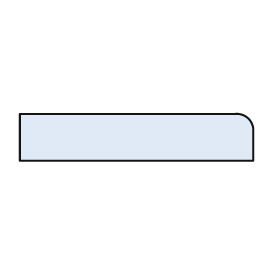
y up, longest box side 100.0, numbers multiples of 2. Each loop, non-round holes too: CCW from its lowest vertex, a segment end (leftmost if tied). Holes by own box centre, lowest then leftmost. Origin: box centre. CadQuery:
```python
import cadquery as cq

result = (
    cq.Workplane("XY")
    .moveTo(-50.0, -10.0)
    .lineTo(50.0, -10.0)
    .lineTo(50.0, 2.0)
    .threePointArc((48.0, 8.0), (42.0, 10.0))
    .lineTo(-50.0, 10.0)
    .close()
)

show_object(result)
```